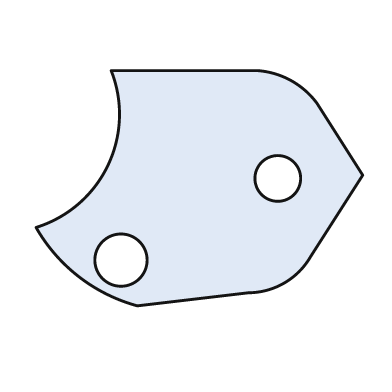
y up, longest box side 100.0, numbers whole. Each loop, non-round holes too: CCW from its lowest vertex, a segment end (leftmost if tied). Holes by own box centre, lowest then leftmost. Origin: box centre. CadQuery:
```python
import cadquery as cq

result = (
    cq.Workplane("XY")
    .moveTo(-19.0, -36.0)
    .lineTo(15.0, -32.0)
    .threePointArc((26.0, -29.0), (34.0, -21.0))
    .lineTo(50.0, 4.0)
    .lineTo(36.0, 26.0)
    .threePointArc((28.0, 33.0), (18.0, 36.0))
    .lineTo(-27.0, 36.0)
    .threePointArc((-28.0, 7.0), (-50.0, -12.0))
    .threePointArc((-37.0, -27.0), (-19.0, -36.0))
    .close()
    .moveTo(-24.0, -22.0)
    .circle(8.0)
    .moveTo(24.0, 3.0)
    .circle(7.0)
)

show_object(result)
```